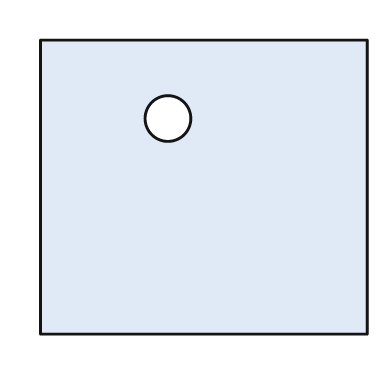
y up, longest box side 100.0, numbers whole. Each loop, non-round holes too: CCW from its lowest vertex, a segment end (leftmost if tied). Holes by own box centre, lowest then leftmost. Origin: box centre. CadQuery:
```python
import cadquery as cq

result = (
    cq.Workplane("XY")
    .moveTo(-50.0, -45.0)
    .lineTo(50.0, -45.0)
    .lineTo(50.0, 45.0)
    .lineTo(-50.0, 45.0)
    .close()
    .moveTo(-11.0, 21.0)
    .circle(7.0)
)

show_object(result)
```